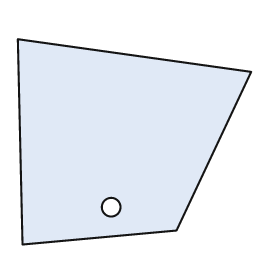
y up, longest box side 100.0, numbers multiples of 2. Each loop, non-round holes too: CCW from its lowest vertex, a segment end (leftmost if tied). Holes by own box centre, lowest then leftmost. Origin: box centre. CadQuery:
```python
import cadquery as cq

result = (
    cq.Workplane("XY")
    .moveTo(-48.0, -44.0)
    .lineTo(18.0, -38.0)
    .lineTo(50.0, 30.0)
    .lineTo(-50.0, 44.0)
    .close()
    .moveTo(-10.0, -28.0)
    .circle(4.0)
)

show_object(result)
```